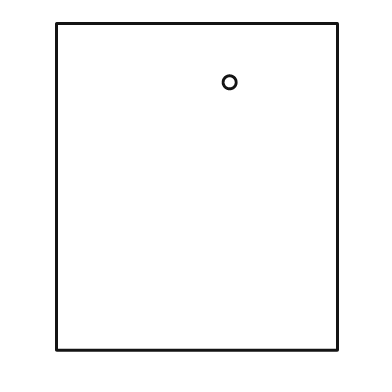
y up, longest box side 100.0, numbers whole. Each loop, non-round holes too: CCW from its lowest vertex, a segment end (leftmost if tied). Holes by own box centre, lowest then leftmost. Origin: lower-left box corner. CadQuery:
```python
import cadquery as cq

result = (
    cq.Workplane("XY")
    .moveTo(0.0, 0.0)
    .lineTo(86.0, 0.0)
    .lineTo(86.0, 100.0)
    .lineTo(0.0, 100.0)
    .close()
    .moveTo(53.0, 82.0)
    .circle(2.0)
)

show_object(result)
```